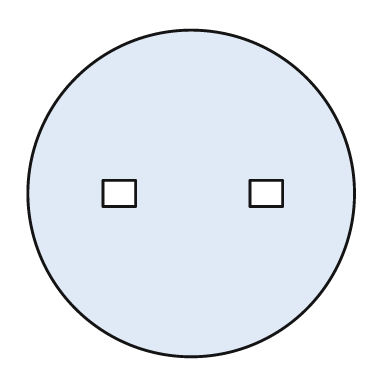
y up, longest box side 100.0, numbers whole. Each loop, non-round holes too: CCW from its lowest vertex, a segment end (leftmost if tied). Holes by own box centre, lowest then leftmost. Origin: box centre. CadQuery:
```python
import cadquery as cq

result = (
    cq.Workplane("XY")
    .moveTo(0.0, 0.0)
    .circle(50.0)
    .moveTo(-27.0, -4.0)
    .lineTo(-17.0, -4.0)
    .lineTo(-17.0, 4.0)
    .lineTo(-27.0, 4.0)
    .close()
    .moveTo(18.0, -4.0)
    .lineTo(28.0, -4.0)
    .lineTo(28.0, 4.0)
    .lineTo(18.0, 4.0)
    .close()
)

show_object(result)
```